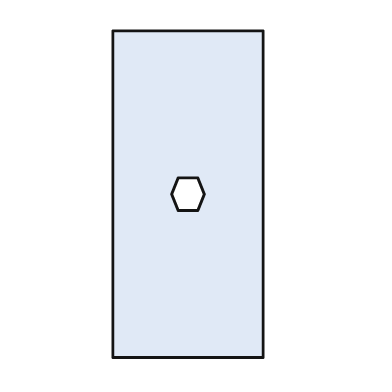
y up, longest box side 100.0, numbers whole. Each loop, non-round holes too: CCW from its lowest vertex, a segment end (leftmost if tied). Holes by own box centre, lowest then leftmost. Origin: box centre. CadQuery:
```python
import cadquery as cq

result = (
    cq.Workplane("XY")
    .moveTo(-23.0, -50.0)
    .lineTo(23.0, -50.0)
    .lineTo(23.0, 50.0)
    .lineTo(-23.0, 50.0)
    .close()
    .moveTo(-3.0, -5.0)
    .lineTo(3.0, -5.0)
    .lineTo(5.0, 0.0)
    .lineTo(3.0, 5.0)
    .lineTo(-3.0, 5.0)
    .lineTo(-5.0, 0.0)
    .close()
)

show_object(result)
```